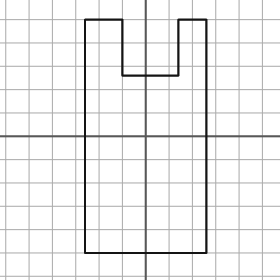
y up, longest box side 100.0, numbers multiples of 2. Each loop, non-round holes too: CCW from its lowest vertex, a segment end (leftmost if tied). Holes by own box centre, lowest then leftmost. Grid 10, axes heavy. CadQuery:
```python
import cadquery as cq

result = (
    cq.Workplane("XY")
    .moveTo(-26.0, -50.0)
    .lineTo(26.0, -50.0)
    .lineTo(26.0, 50.0)
    .lineTo(14.0, 50.0)
    .lineTo(14.0, 26.0)
    .lineTo(-10.0, 26.0)
    .lineTo(-10.0, 50.0)
    .lineTo(-26.0, 50.0)
    .close()
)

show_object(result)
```